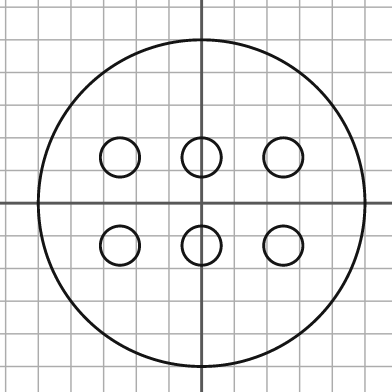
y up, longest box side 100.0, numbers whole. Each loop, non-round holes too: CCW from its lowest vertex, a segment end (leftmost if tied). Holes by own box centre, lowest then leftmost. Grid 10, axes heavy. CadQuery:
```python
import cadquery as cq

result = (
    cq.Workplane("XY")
    .moveTo(0.0, 0.0)
    .circle(50.0)
    .moveTo(-25.0, -13.0)
    .circle(6.0)
    .moveTo(0.0, -13.0)
    .circle(6.0)
    .moveTo(25.0, -13.0)
    .circle(6.0)
    .moveTo(-25.0, 14.0)
    .circle(6.0)
    .moveTo(0.0, 14.0)
    .circle(6.0)
    .moveTo(25.0, 14.0)
    .circle(6.0)
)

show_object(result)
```